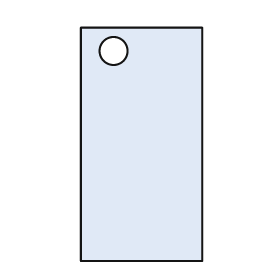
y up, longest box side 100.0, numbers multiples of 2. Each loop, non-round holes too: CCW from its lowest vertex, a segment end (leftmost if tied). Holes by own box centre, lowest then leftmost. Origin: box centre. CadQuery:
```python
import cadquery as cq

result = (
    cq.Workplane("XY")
    .moveTo(-26.0, -50.0)
    .lineTo(26.0, -50.0)
    .lineTo(26.0, 50.0)
    .lineTo(-26.0, 50.0)
    .close()
    .moveTo(-12.0, 40.0)
    .circle(6.0)
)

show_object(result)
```